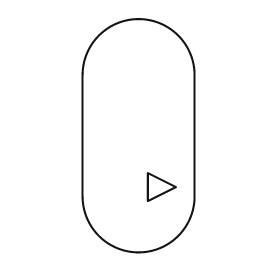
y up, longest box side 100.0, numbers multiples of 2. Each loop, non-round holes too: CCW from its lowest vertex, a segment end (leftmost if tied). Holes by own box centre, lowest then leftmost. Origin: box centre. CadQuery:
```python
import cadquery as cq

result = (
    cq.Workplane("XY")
    .moveTo(-24.0, -26.0)
    .threePointArc((0.0, -50.0), (24.0, -26.0))
    .lineTo(24.0, 26.0)
    .threePointArc((0.0, 50.0), (-24.0, 26.0))
    .close()
    .moveTo(4.0, -28.0)
    .lineTo(16.0, -22.0)
    .lineTo(4.0, -16.0)
    .close()
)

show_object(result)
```